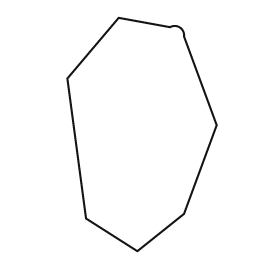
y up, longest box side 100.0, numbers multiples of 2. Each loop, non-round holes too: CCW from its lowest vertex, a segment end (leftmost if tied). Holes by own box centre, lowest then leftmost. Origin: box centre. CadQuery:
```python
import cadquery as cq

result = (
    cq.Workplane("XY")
    .moveTo(-2.0, -50.0)
    .lineTo(18.0, -34.0)
    .lineTo(32.0, 4.0)
    .lineTo(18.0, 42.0)
    .threePointArc((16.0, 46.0), (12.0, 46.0))
    .lineTo(-10.0, 50.0)
    .lineTo(-32.0, 24.0)
    .lineTo(-24.0, -36.0)
    .close()
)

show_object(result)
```